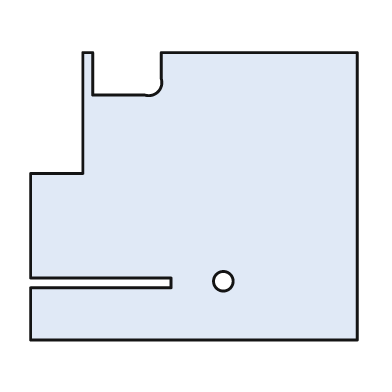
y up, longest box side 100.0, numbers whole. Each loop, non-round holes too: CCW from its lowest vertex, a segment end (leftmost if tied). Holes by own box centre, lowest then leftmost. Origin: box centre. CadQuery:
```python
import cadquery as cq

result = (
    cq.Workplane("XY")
    .moveTo(-50.0, -44.0)
    .lineTo(50.0, -44.0)
    .lineTo(50.0, 44.0)
    .lineTo(-10.0, 44.0)
    .lineTo(-10.0, 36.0)
    .threePointArc((-11.0, 32.0), (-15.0, 31.0))
    .lineTo(-31.0, 31.0)
    .lineTo(-31.0, 44.0)
    .lineTo(-34.0, 44.0)
    .lineTo(-34.0, 7.0)
    .lineTo(-50.0, 7.0)
    .lineTo(-50.0, -25.0)
    .lineTo(-7.0, -25.0)
    .lineTo(-7.0, -28.0)
    .lineTo(-50.0, -28.0)
    .close()
    .moveTo(9.0, -26.0)
    .circle(3.0)
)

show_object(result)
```